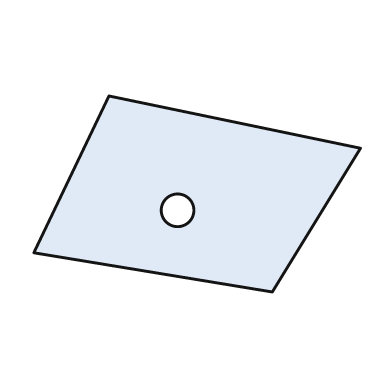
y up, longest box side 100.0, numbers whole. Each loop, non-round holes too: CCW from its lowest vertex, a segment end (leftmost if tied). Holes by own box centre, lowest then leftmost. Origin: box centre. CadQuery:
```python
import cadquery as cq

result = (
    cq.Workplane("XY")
    .moveTo(23.0, -30.0)
    .lineTo(50.0, 14.0)
    .lineTo(-27.0, 30.0)
    .lineTo(-50.0, -18.0)
    .close()
    .moveTo(-6.0, -5.0)
    .circle(5.0)
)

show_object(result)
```